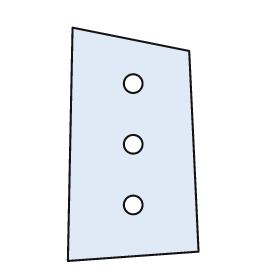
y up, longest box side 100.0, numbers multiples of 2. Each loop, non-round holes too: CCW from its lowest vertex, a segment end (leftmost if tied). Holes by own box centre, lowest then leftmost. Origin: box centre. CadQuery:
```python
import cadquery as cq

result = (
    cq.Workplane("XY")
    .moveTo(-28.0, -50.0)
    .lineTo(28.0, -46.0)
    .lineTo(24.0, 40.0)
    .lineTo(-26.0, 50.0)
    .close()
    .moveTo(0.0, -26.0)
    .circle(4.0)
    .moveTo(0.0, 0.0)
    .circle(4.0)
    .moveTo(0.0, 26.0)
    .circle(4.0)
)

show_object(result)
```